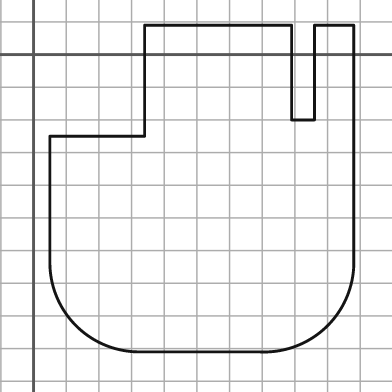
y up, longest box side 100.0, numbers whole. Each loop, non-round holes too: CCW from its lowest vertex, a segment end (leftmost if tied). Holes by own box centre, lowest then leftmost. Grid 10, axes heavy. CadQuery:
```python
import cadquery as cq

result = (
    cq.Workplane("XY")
    .moveTo(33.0, -91.0)
    .lineTo(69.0, -91.0)
    .threePointArc((90.0, -83.0), (98.0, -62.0))
    .lineTo(98.0, 9.0)
    .lineTo(86.0, 9.0)
    .lineTo(86.0, -20.0)
    .lineTo(79.0, -20.0)
    .lineTo(79.0, 9.0)
    .lineTo(34.0, 9.0)
    .lineTo(34.0, -25.0)
    .lineTo(5.0, -25.0)
    .lineTo(5.0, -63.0)
    .threePointArc((13.0, -83.0), (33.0, -91.0))
    .close()
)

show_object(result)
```